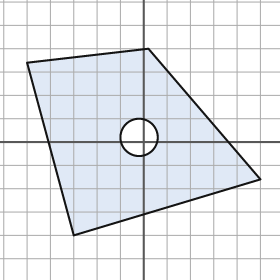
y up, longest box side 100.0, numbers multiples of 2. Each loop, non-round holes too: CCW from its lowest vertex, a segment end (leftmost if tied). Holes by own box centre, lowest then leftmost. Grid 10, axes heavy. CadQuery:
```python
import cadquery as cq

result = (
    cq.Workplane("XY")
    .moveTo(-30.0, -40.0)
    .lineTo(50.0, -16.0)
    .lineTo(2.0, 40.0)
    .lineTo(-50.0, 34.0)
    .close()
    .moveTo(-2.0, 2.0)
    .circle(8.0)
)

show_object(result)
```